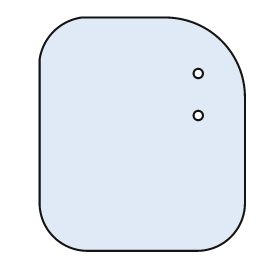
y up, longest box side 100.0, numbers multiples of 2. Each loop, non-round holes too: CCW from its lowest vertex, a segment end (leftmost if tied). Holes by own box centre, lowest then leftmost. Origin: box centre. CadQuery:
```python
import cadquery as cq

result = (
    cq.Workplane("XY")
    .moveTo(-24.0, -50.0)
    .lineTo(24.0, -50.0)
    .threePointArc((38.0, -44.0), (44.0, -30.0))
    .lineTo(44.0, 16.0)
    .threePointArc((34.0, 40.0), (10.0, 50.0))
    .lineTo(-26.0, 50.0)
    .threePointArc((-38.0, 44.0), (-44.0, 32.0))
    .lineTo(-44.0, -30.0)
    .threePointArc((-38.0, -44.0), (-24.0, -50.0))
    .close()
    .moveTo(24.0, 8.0)
    .circle(2.0)
    .moveTo(24.0, 26.0)
    .circle(2.0)
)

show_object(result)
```